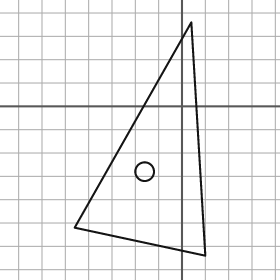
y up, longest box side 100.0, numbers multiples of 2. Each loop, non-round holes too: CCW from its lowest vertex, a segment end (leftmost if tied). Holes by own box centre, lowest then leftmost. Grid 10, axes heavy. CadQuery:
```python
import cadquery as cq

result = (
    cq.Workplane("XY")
    .moveTo(10.0, -64.0)
    .lineTo(4.0, 36.0)
    .lineTo(-46.0, -52.0)
    .close()
    .moveTo(-16.0, -28.0)
    .circle(4.0)
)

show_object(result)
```